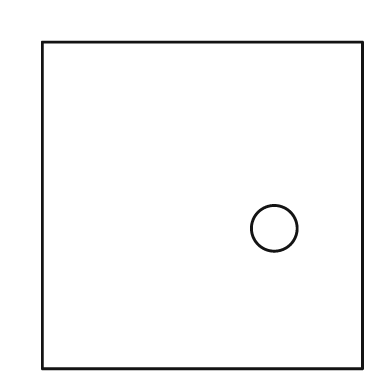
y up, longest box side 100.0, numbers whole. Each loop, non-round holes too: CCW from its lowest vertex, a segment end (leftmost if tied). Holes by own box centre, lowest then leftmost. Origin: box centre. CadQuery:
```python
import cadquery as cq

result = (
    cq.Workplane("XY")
    .moveTo(-49.0, -50.0)
    .lineTo(49.0, -50.0)
    .lineTo(49.0, 50.0)
    .lineTo(-49.0, 50.0)
    .close()
    .moveTo(22.0, -7.0)
    .circle(7.0)
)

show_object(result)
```